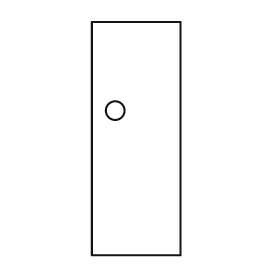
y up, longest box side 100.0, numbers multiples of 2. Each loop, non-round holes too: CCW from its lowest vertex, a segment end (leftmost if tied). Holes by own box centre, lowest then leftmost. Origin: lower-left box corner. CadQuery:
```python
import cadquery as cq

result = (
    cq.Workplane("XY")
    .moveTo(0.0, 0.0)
    .lineTo(38.0, 0.0)
    .lineTo(38.0, 100.0)
    .lineTo(0.0, 100.0)
    .close()
    .moveTo(10.0, 62.0)
    .circle(4.0)
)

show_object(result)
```